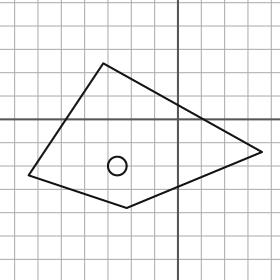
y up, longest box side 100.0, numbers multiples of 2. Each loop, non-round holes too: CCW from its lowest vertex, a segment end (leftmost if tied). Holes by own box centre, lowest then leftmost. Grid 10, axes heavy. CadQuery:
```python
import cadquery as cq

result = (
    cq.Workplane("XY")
    .moveTo(-22.0, -38.0)
    .lineTo(36.0, -14.0)
    .lineTo(-32.0, 24.0)
    .lineTo(-64.0, -24.0)
    .close()
    .moveTo(-26.0, -20.0)
    .circle(4.0)
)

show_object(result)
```